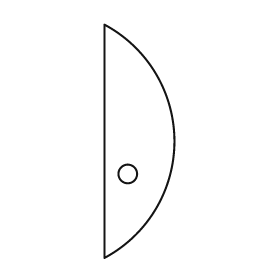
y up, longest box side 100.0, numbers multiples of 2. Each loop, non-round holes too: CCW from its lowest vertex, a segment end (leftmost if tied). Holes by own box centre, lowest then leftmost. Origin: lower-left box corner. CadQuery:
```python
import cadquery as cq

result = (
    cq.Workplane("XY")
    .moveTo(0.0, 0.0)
    .threePointArc((30.0, 50.0), (0.0, 100.0))
    .close()
    .moveTo(10.0, 36.0)
    .circle(4.0)
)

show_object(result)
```